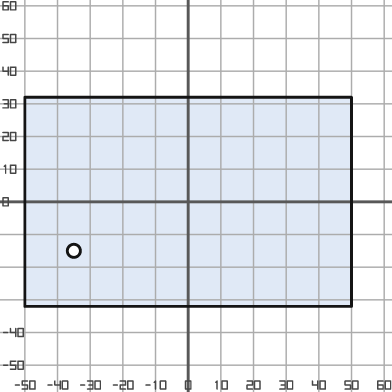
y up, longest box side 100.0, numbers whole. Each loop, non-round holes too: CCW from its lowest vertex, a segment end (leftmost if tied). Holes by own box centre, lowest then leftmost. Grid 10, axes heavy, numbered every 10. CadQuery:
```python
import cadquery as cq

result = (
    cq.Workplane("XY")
    .moveTo(-50.0, -32.0)
    .lineTo(50.0, -32.0)
    .lineTo(50.0, 32.0)
    .lineTo(-50.0, 32.0)
    .close()
    .moveTo(-35.0, -15.0)
    .circle(2.0)
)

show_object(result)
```